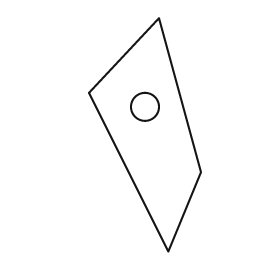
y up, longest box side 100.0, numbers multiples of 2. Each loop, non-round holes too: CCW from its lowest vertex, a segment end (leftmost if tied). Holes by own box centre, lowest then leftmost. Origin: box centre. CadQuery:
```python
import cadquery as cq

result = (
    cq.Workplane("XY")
    .moveTo(10.0, -50.0)
    .lineTo(24.0, -16.0)
    .lineTo(6.0, 50.0)
    .lineTo(-24.0, 18.0)
    .close()
    .moveTo(0.0, 12.0)
    .circle(6.0)
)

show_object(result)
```